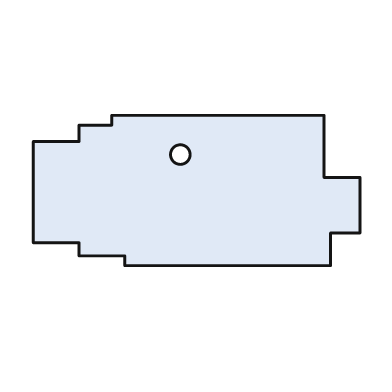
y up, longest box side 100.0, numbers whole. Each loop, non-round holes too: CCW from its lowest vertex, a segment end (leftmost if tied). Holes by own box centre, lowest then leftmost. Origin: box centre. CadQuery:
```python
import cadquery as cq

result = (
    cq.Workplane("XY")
    .moveTo(-22.0, -23.0)
    .lineTo(41.0, -23.0)
    .lineTo(41.0, -13.0)
    .lineTo(50.0, -13.0)
    .lineTo(50.0, 4.0)
    .lineTo(39.0, 4.0)
    .lineTo(39.0, 23.0)
    .lineTo(-26.0, 23.0)
    .lineTo(-26.0, 20.0)
    .lineTo(-36.0, 20.0)
    .lineTo(-36.0, 15.0)
    .lineTo(-50.0, 15.0)
    .lineTo(-50.0, -16.0)
    .lineTo(-36.0, -16.0)
    .lineTo(-36.0, -20.0)
    .lineTo(-22.0, -20.0)
    .close()
    .moveTo(-5.0, 11.0)
    .circle(3.0)
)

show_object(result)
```